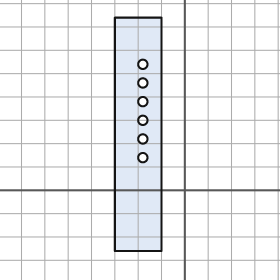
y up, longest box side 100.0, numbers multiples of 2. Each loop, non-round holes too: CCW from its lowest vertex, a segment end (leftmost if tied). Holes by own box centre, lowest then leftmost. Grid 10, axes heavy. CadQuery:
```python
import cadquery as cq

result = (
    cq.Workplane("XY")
    .moveTo(-30.0, -26.0)
    .lineTo(-10.0, -26.0)
    .lineTo(-10.0, 74.0)
    .lineTo(-30.0, 74.0)
    .close()
    .moveTo(-18.0, 14.0)
    .circle(2.0)
    .moveTo(-18.0, 22.0)
    .circle(2.0)
    .moveTo(-18.0, 30.0)
    .circle(2.0)
    .moveTo(-18.0, 38.0)
    .circle(2.0)
    .moveTo(-18.0, 46.0)
    .circle(2.0)
    .moveTo(-18.0, 54.0)
    .circle(2.0)
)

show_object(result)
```